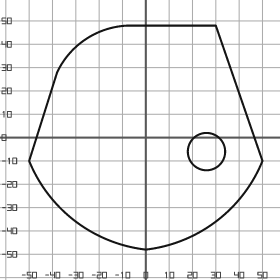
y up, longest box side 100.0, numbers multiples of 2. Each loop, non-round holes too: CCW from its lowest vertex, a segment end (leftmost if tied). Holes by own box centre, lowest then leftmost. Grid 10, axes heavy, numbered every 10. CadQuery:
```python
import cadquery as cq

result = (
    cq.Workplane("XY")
    .moveTo(0.0, -48.0)
    .threePointArc((30.0, -36.0), (50.0, -10.0))
    .lineTo(30.0, 48.0)
    .lineTo(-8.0, 48.0)
    .threePointArc((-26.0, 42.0), (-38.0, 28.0))
    .lineTo(-50.0, -10.0)
    .threePointArc((-30.0, -36.0), (0.0, -48.0))
    .close()
    .moveTo(26.0, -6.0)
    .circle(8.0)
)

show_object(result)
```